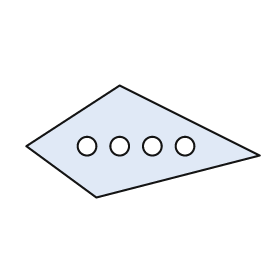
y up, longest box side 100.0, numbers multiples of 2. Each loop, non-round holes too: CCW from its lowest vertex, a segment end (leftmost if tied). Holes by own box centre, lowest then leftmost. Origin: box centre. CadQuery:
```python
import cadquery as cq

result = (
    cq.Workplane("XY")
    .moveTo(-20.0, -24.0)
    .lineTo(50.0, -6.0)
    .lineTo(-10.0, 24.0)
    .lineTo(-50.0, -2.0)
    .close()
    .moveTo(-24.0, -2.0)
    .circle(4.0)
    .moveTo(-10.0, -2.0)
    .circle(4.0)
    .moveTo(4.0, -2.0)
    .circle(4.0)
    .moveTo(18.0, -2.0)
    .circle(4.0)
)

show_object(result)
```